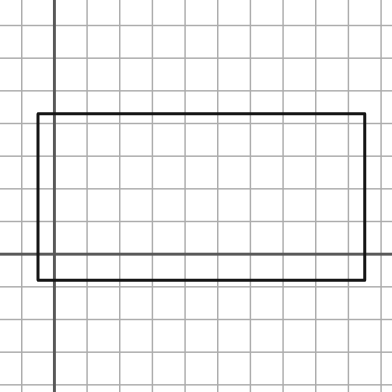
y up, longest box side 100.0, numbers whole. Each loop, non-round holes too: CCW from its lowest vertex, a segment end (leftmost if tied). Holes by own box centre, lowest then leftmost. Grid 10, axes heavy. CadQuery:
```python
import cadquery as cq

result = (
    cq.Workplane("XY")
    .moveTo(-5.0, -8.0)
    .lineTo(95.0, -8.0)
    .lineTo(95.0, 43.0)
    .lineTo(-5.0, 43.0)
    .close()
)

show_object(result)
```